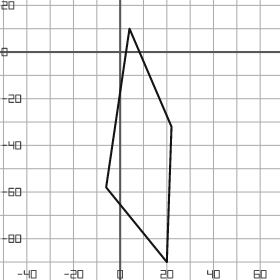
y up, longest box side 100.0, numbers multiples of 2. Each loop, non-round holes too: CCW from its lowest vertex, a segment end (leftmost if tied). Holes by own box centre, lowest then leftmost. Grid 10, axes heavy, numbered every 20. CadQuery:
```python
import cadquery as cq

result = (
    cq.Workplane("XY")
    .moveTo(20.0, -90.0)
    .lineTo(22.0, -32.0)
    .lineTo(4.0, 10.0)
    .lineTo(-6.0, -58.0)
    .close()
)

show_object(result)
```